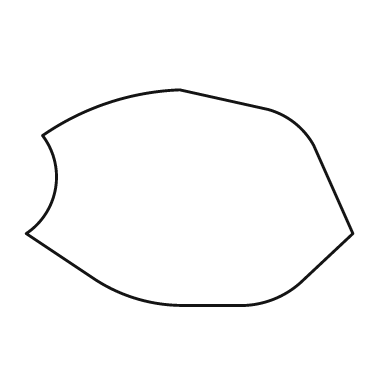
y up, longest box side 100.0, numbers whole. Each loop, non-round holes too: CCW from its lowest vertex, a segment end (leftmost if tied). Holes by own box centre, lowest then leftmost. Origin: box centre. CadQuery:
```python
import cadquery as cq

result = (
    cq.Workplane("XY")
    .moveTo(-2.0, -33.0)
    .lineTo(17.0, -33.0)
    .threePointArc((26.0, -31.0), (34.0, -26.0))
    .lineTo(50.0, -11.0)
    .lineTo(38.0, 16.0)
    .threePointArc((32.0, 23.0), (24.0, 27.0))
    .lineTo(-3.0, 33.0)
    .threePointArc((-25.0, 29.0), (-45.0, 19.0))
    .threePointArc((-41.0, 3.0), (-50.0, -11.0))
    .lineTo(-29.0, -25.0)
    .threePointArc((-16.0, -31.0), (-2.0, -33.0))
    .close()
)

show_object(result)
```